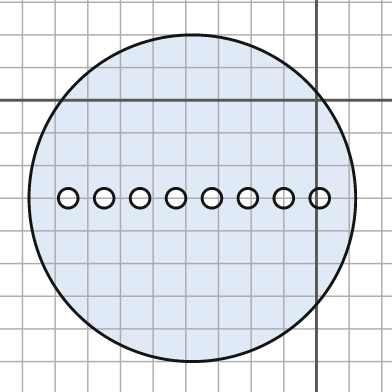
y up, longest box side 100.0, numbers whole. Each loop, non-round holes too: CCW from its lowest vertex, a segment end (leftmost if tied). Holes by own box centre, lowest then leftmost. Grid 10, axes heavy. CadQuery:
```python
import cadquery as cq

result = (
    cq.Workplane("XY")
    .moveTo(-38.0, -30.0)
    .circle(50.0)
    .moveTo(-76.0, -30.0)
    .circle(3.0)
    .moveTo(-65.0, -30.0)
    .circle(3.0)
    .moveTo(-54.0, -30.0)
    .circle(3.0)
    .moveTo(-43.0, -30.0)
    .circle(3.0)
    .moveTo(-32.0, -30.0)
    .circle(3.0)
    .moveTo(-21.0, -30.0)
    .circle(3.0)
    .moveTo(-10.0, -30.0)
    .circle(3.0)
    .moveTo(1.0, -30.0)
    .circle(3.0)
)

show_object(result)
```